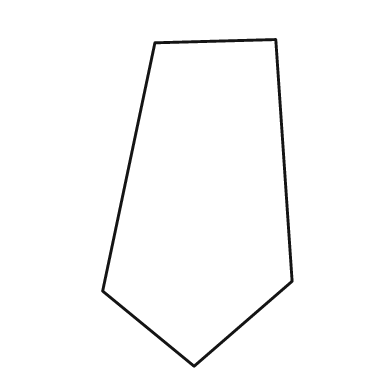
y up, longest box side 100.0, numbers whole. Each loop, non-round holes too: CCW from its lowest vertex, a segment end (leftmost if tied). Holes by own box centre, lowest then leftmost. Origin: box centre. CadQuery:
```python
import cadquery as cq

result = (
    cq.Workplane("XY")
    .moveTo(-1.0, -50.0)
    .lineTo(29.0, -24.0)
    .lineTo(24.0, 50.0)
    .lineTo(-13.0, 49.0)
    .lineTo(-29.0, -27.0)
    .close()
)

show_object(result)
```